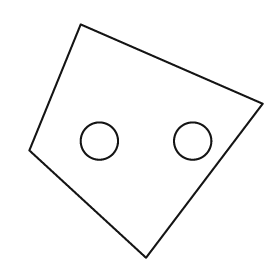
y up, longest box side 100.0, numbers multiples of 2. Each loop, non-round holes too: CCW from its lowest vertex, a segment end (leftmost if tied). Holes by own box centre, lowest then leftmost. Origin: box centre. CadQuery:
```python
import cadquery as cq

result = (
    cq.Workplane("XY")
    .moveTo(0.0, -50.0)
    .lineTo(50.0, 16.0)
    .lineTo(-28.0, 50.0)
    .lineTo(-50.0, -4.0)
    .close()
    .moveTo(-20.0, 0.0)
    .circle(8.0)
    .moveTo(20.0, 0.0)
    .circle(8.0)
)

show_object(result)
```